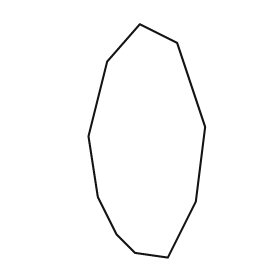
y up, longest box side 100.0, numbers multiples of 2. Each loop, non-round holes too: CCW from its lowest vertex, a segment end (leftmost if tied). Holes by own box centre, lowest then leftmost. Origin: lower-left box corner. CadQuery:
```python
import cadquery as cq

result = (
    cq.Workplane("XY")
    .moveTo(34.0, 0.0)
    .lineTo(46.0, 24.0)
    .lineTo(50.0, 56.0)
    .lineTo(38.0, 92.0)
    .lineTo(22.0, 100.0)
    .lineTo(8.0, 84.0)
    .lineTo(0.0, 52.0)
    .lineTo(4.0, 26.0)
    .lineTo(12.0, 10.0)
    .lineTo(20.0, 2.0)
    .close()
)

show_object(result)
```